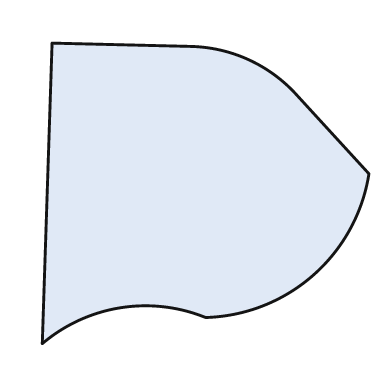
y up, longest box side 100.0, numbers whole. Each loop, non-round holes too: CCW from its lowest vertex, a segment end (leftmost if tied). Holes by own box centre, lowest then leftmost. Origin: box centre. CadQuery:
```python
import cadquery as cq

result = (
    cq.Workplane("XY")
    .moveTo(-50.0, -46.0)
    .threePointArc((-26.0, -35.0), (0.0, -38.0))
    .threePointArc((33.0, -25.0), (50.0, 6.0))
    .lineTo(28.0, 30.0)
    .threePointArc((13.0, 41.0), (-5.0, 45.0))
    .lineTo(-47.0, 46.0)
    .close()
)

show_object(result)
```